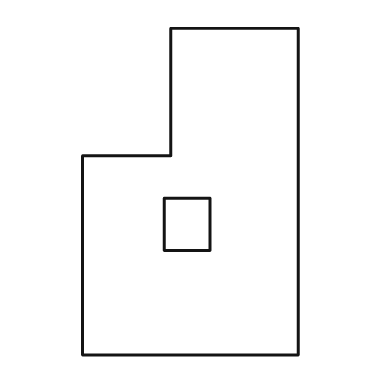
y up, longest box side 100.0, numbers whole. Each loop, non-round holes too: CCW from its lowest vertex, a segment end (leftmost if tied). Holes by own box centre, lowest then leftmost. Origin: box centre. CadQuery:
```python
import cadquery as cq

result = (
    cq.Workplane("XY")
    .moveTo(-33.0, -50.0)
    .lineTo(33.0, -50.0)
    .lineTo(33.0, 50.0)
    .lineTo(-6.0, 50.0)
    .lineTo(-6.0, 11.0)
    .lineTo(-33.0, 11.0)
    .close()
    .moveTo(-8.0, -18.0)
    .lineTo(6.0, -18.0)
    .lineTo(6.0, -2.0)
    .lineTo(-8.0, -2.0)
    .close()
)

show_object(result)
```